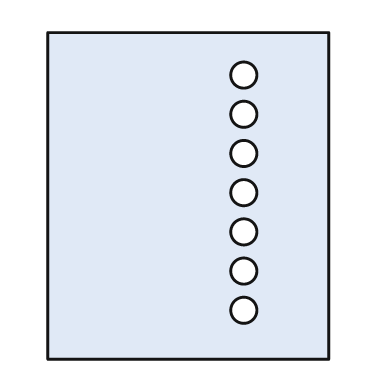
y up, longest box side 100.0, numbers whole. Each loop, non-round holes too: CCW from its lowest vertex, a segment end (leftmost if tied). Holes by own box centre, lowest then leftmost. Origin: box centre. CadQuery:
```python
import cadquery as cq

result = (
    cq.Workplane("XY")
    .moveTo(-43.0, -50.0)
    .lineTo(43.0, -50.0)
    .lineTo(43.0, 50.0)
    .lineTo(-43.0, 50.0)
    .close()
    .moveTo(17.0, -35.0)
    .circle(4.0)
    .moveTo(17.0, -23.0)
    .circle(4.0)
    .moveTo(17.0, -11.0)
    .circle(4.0)
    .moveTo(17.0, 1.0)
    .circle(4.0)
    .moveTo(17.0, 13.0)
    .circle(4.0)
    .moveTo(17.0, 25.0)
    .circle(4.0)
    .moveTo(17.0, 37.0)
    .circle(4.0)
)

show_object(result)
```